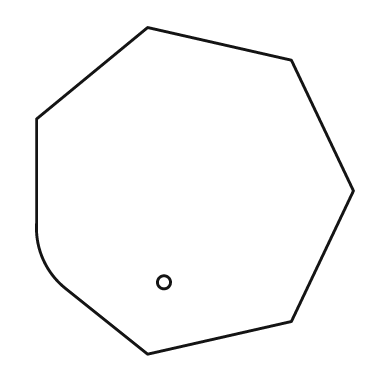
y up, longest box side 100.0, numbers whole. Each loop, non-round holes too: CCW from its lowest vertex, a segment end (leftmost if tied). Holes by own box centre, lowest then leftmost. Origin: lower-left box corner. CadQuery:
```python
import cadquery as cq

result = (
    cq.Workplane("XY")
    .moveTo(34.0, 0.0)
    .lineTo(78.0, 10.0)
    .lineTo(97.0, 50.0)
    .lineTo(78.0, 90.0)
    .lineTo(34.0, 100.0)
    .lineTo(0.0, 72.0)
    .lineTo(0.0, 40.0)
    .threePointArc((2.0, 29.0), (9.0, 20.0))
    .close()
    .moveTo(39.0, 22.0)
    .circle(2.0)
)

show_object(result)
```